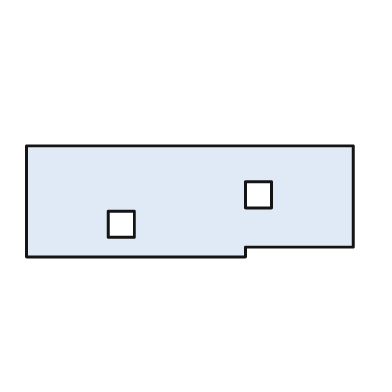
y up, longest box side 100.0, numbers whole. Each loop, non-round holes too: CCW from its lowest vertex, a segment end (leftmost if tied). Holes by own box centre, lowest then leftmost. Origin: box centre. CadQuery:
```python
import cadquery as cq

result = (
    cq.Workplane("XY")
    .moveTo(-50.0, -17.0)
    .lineTo(17.0, -17.0)
    .lineTo(17.0, -14.0)
    .lineTo(50.0, -14.0)
    .lineTo(50.0, 17.0)
    .lineTo(-50.0, 17.0)
    .close()
    .moveTo(-25.0, -11.0)
    .lineTo(-17.0, -11.0)
    .lineTo(-17.0, -3.0)
    .lineTo(-25.0, -3.0)
    .close()
    .moveTo(17.0, -2.0)
    .lineTo(25.0, -2.0)
    .lineTo(25.0, 6.0)
    .lineTo(17.0, 6.0)
    .close()
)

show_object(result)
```